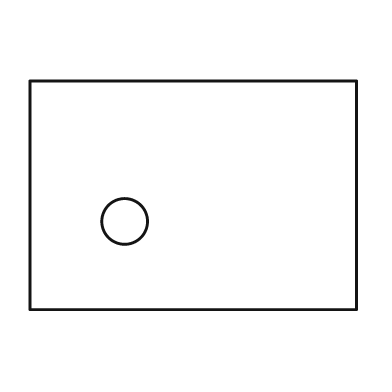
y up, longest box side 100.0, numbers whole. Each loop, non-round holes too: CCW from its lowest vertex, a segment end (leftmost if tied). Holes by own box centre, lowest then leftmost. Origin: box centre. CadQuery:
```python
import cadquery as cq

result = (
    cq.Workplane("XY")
    .moveTo(-50.0, -35.0)
    .lineTo(50.0, -35.0)
    .lineTo(50.0, 35.0)
    .lineTo(-50.0, 35.0)
    .close()
    .moveTo(-21.0, -8.0)
    .circle(7.0)
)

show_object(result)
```